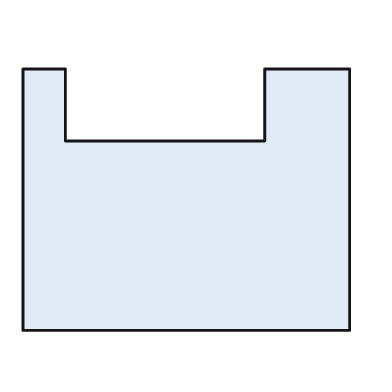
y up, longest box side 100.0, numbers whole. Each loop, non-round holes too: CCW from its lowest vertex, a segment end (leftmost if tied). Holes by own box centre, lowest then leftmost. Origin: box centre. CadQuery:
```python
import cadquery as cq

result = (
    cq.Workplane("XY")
    .moveTo(-50.0, -40.0)
    .lineTo(50.0, -40.0)
    .lineTo(50.0, 40.0)
    .lineTo(24.0, 40.0)
    .lineTo(24.0, 18.0)
    .lineTo(-37.0, 18.0)
    .lineTo(-37.0, 40.0)
    .lineTo(-50.0, 40.0)
    .close()
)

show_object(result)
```